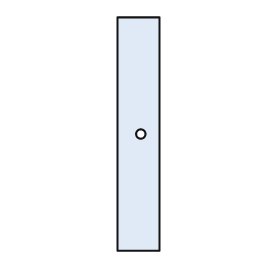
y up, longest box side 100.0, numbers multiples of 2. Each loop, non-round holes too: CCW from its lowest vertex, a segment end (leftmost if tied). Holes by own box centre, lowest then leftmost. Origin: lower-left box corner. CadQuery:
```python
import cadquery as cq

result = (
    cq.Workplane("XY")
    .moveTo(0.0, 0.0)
    .lineTo(18.0, 0.0)
    .lineTo(18.0, 100.0)
    .lineTo(0.0, 100.0)
    .close()
    .moveTo(10.0, 50.0)
    .circle(2.0)
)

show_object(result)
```